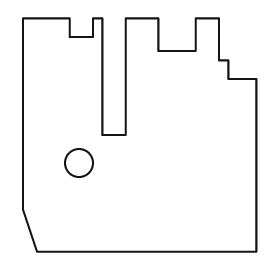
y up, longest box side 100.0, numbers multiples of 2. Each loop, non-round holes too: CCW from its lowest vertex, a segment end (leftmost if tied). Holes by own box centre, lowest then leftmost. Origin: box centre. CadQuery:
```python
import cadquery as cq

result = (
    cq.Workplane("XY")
    .moveTo(-44.0, -50.0)
    .lineTo(50.0, -50.0)
    .lineTo(50.0, 24.0)
    .lineTo(38.0, 24.0)
    .lineTo(38.0, 32.0)
    .lineTo(34.0, 32.0)
    .lineTo(34.0, 50.0)
    .lineTo(24.0, 50.0)
    .lineTo(24.0, 36.0)
    .lineTo(8.0, 36.0)
    .lineTo(8.0, 50.0)
    .lineTo(-6.0, 50.0)
    .lineTo(-6.0, 0.0)
    .lineTo(-16.0, 0.0)
    .lineTo(-16.0, 50.0)
    .lineTo(-20.0, 50.0)
    .lineTo(-20.0, 42.0)
    .lineTo(-30.0, 42.0)
    .lineTo(-30.0, 50.0)
    .lineTo(-50.0, 50.0)
    .lineTo(-50.0, -32.0)
    .close()
    .moveTo(-26.0, -12.0)
    .circle(6.0)
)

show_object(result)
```